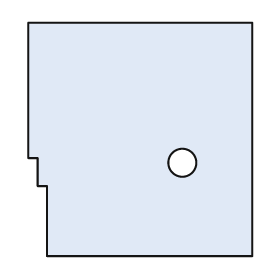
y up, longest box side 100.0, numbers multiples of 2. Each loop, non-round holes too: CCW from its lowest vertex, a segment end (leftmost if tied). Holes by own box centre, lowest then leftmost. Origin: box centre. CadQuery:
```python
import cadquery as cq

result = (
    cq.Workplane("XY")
    .moveTo(-40.0, -50.0)
    .lineTo(48.0, -50.0)
    .lineTo(48.0, 50.0)
    .lineTo(-48.0, 50.0)
    .lineTo(-48.0, -8.0)
    .lineTo(-44.0, -8.0)
    .lineTo(-44.0, -20.0)
    .lineTo(-40.0, -20.0)
    .close()
    .moveTo(18.0, -10.0)
    .circle(6.0)
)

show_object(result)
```